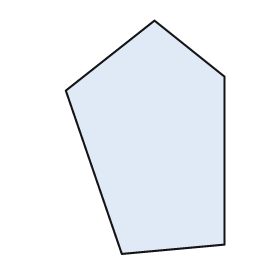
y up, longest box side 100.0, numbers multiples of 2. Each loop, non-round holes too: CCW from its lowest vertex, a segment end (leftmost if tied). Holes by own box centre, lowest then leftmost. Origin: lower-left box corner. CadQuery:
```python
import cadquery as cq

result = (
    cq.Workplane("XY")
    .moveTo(24.0, 0.0)
    .lineTo(68.0, 4.0)
    .lineTo(68.0, 76.0)
    .lineTo(38.0, 100.0)
    .lineTo(0.0, 70.0)
    .close()
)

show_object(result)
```